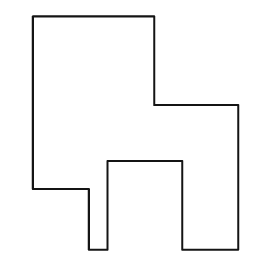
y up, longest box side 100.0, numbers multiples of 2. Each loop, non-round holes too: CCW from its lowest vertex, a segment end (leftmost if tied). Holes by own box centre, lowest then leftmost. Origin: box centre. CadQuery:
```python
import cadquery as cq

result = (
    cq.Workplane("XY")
    .moveTo(-20.0, -50.0)
    .lineTo(-12.0, -50.0)
    .lineTo(-12.0, -12.0)
    .lineTo(20.0, -12.0)
    .lineTo(20.0, -50.0)
    .lineTo(44.0, -50.0)
    .lineTo(44.0, 12.0)
    .lineTo(8.0, 12.0)
    .lineTo(8.0, 50.0)
    .lineTo(-44.0, 50.0)
    .lineTo(-44.0, -24.0)
    .lineTo(-20.0, -24.0)
    .close()
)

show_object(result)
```